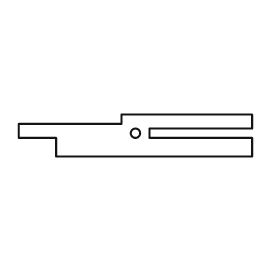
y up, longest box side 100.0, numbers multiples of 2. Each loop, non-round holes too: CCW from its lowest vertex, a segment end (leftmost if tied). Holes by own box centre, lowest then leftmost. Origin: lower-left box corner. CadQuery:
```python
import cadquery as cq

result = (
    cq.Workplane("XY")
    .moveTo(16.0, 0.0)
    .lineTo(100.0, 0.0)
    .lineTo(100.0, 8.0)
    .lineTo(56.0, 8.0)
    .lineTo(56.0, 12.0)
    .lineTo(100.0, 12.0)
    .lineTo(100.0, 18.0)
    .lineTo(44.0, 18.0)
    .lineTo(44.0, 14.0)
    .lineTo(0.0, 14.0)
    .lineTo(0.0, 8.0)
    .lineTo(16.0, 8.0)
    .close()
    .moveTo(50.0, 10.0)
    .circle(2.0)
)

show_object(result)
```